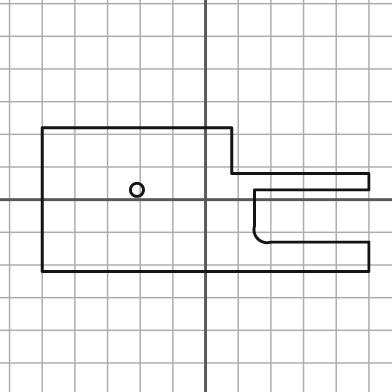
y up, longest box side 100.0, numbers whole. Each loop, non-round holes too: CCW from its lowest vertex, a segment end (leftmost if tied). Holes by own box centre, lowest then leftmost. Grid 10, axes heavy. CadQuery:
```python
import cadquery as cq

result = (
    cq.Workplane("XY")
    .moveTo(-50.0, -22.0)
    .lineTo(50.0, -22.0)
    .lineTo(50.0, -13.0)
    .lineTo(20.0, -13.0)
    .threePointArc((16.0, -12.0), (15.0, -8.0))
    .lineTo(15.0, 3.0)
    .lineTo(50.0, 3.0)
    .lineTo(50.0, 8.0)
    .lineTo(8.0, 8.0)
    .lineTo(8.0, 22.0)
    .lineTo(-50.0, 22.0)
    .close()
    .moveTo(-21.0, 3.0)
    .circle(2.0)
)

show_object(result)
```